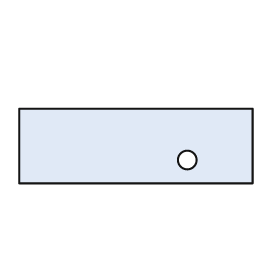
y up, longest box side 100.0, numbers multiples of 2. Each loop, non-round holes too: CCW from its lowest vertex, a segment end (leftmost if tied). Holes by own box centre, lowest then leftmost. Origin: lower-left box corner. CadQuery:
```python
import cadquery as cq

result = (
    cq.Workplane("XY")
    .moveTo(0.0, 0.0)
    .lineTo(100.0, 0.0)
    .lineTo(100.0, 32.0)
    .lineTo(0.0, 32.0)
    .close()
    .moveTo(72.0, 10.0)
    .circle(4.0)
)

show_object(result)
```